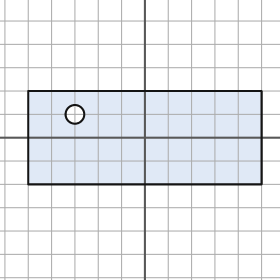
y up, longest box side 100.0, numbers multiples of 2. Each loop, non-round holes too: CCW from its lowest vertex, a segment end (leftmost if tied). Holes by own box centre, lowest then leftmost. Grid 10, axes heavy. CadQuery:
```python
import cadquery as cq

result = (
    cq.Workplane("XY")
    .moveTo(-50.0, -20.0)
    .lineTo(50.0, -20.0)
    .lineTo(50.0, 20.0)
    .lineTo(-50.0, 20.0)
    .close()
    .moveTo(-30.0, 10.0)
    .circle(4.0)
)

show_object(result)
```